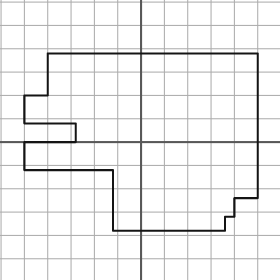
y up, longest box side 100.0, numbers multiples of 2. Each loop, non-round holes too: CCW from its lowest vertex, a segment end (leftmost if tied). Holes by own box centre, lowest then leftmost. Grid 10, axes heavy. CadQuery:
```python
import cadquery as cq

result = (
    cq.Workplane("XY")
    .moveTo(-12.0, -38.0)
    .lineTo(36.0, -38.0)
    .lineTo(36.0, -32.0)
    .lineTo(40.0, -32.0)
    .lineTo(40.0, -24.0)
    .lineTo(50.0, -24.0)
    .lineTo(50.0, 38.0)
    .lineTo(-40.0, 38.0)
    .lineTo(-40.0, 20.0)
    .lineTo(-50.0, 20.0)
    .lineTo(-50.0, 8.0)
    .lineTo(-28.0, 8.0)
    .lineTo(-28.0, 0.0)
    .lineTo(-50.0, 0.0)
    .lineTo(-50.0, -12.0)
    .lineTo(-12.0, -12.0)
    .close()
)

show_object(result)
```